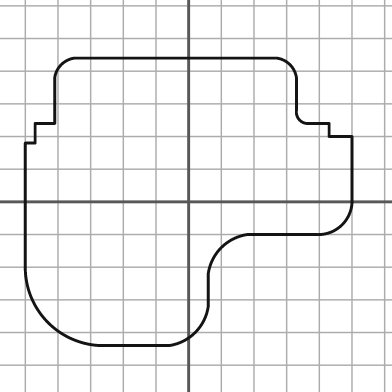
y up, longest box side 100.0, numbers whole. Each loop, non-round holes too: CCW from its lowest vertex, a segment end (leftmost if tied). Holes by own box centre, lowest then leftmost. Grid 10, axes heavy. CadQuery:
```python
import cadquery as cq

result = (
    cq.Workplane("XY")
    .moveTo(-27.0, -44.0)
    .lineTo(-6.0, -44.0)
    .threePointArc((2.0, -40.0), (6.0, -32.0))
    .lineTo(6.0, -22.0)
    .threePointArc((10.0, -14.0), (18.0, -10.0))
    .lineTo(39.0, -10.0)
    .threePointArc((47.0, -7.0), (50.0, 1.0))
    .lineTo(50.0, 20.0)
    .lineTo(43.0, 20.0)
    .lineTo(43.0, 24.0)
    .lineTo(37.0, 24.0)
    .threePointArc((34.0, 25.0), (33.0, 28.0))
    .lineTo(33.0, 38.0)
    .threePointArc((31.0, 42.0), (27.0, 44.0))
    .lineTo(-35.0, 44.0)
    .threePointArc((-39.0, 42.0), (-41.0, 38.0))
    .lineTo(-41.0, 24.0)
    .lineTo(-47.0, 24.0)
    .lineTo(-47.0, 18.0)
    .lineTo(-50.0, 18.0)
    .lineTo(-50.0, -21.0)
    .threePointArc((-43.0, -37.0), (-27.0, -44.0))
    .close()
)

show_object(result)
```